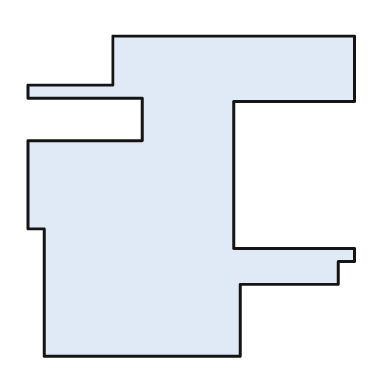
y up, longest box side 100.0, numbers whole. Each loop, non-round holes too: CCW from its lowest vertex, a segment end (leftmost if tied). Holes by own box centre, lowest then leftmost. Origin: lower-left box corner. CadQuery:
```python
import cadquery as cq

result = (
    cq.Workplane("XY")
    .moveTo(5.0, 0.0)
    .lineTo(65.0, 0.0)
    .lineTo(65.0, 22.0)
    .lineTo(95.0, 22.0)
    .lineTo(95.0, 29.0)
    .lineTo(100.0, 29.0)
    .lineTo(100.0, 33.0)
    .lineTo(63.0, 33.0)
    .lineTo(63.0, 78.0)
    .lineTo(100.0, 78.0)
    .lineTo(100.0, 98.0)
    .lineTo(26.0, 98.0)
    .lineTo(26.0, 83.0)
    .lineTo(0.0, 83.0)
    .lineTo(0.0, 79.0)
    .lineTo(35.0, 79.0)
    .lineTo(35.0, 66.0)
    .lineTo(0.0, 66.0)
    .lineTo(0.0, 39.0)
    .lineTo(5.0, 39.0)
    .close()
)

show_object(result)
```